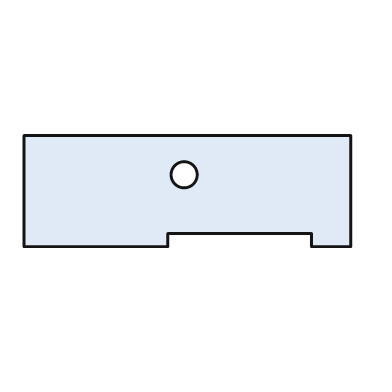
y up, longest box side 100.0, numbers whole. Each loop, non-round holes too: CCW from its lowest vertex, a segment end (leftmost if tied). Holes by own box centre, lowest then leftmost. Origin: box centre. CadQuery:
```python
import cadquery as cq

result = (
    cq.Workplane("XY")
    .moveTo(-50.0, -17.0)
    .lineTo(-6.0, -17.0)
    .lineTo(-6.0, -13.0)
    .lineTo(38.0, -13.0)
    .lineTo(38.0, -17.0)
    .lineTo(50.0, -17.0)
    .lineTo(50.0, 17.0)
    .lineTo(-50.0, 17.0)
    .close()
    .moveTo(-1.0, 5.0)
    .circle(4.0)
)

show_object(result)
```